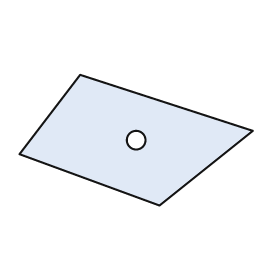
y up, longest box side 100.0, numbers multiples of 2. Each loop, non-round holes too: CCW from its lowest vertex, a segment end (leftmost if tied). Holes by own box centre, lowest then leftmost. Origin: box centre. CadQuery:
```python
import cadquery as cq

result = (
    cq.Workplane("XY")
    .moveTo(10.0, -28.0)
    .lineTo(50.0, 4.0)
    .lineTo(-24.0, 28.0)
    .lineTo(-50.0, -6.0)
    .close()
    .moveTo(0.0, 0.0)
    .circle(4.0)
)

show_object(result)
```